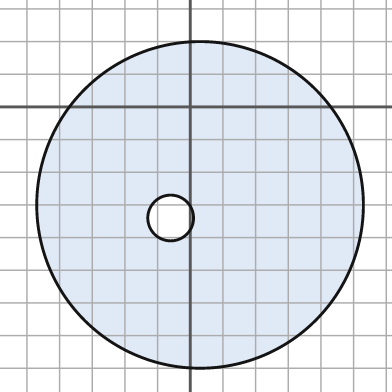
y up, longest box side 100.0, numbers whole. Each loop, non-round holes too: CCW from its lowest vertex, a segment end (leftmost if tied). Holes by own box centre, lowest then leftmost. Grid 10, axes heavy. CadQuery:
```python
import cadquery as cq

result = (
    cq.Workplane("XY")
    .moveTo(3.0, -30.0)
    .circle(50.0)
    .moveTo(-6.0, -34.0)
    .circle(7.0)
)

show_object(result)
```